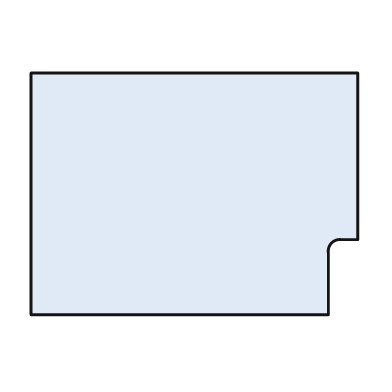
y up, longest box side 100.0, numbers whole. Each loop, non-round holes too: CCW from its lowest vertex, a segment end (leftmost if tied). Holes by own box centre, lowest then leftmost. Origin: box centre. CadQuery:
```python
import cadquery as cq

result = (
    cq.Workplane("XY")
    .moveTo(-50.0, -37.0)
    .lineTo(41.0, -37.0)
    .lineTo(41.0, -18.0)
    .threePointArc((42.0, -15.0), (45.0, -14.0))
    .lineTo(50.0, -14.0)
    .lineTo(50.0, 37.0)
    .lineTo(-50.0, 37.0)
    .close()
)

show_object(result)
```